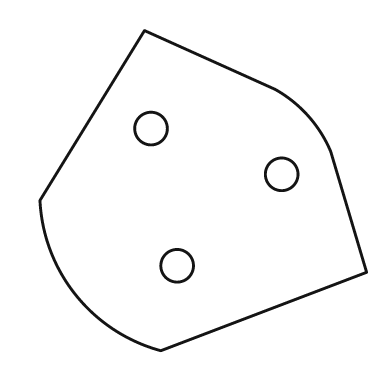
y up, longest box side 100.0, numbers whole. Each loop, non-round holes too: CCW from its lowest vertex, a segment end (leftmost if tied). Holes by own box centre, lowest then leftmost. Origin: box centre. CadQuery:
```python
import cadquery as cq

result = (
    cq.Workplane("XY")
    .moveTo(-13.0, -49.0)
    .lineTo(50.0, -25.0)
    .lineTo(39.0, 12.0)
    .threePointArc((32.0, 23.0), (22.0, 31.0))
    .lineTo(-18.0, 49.0)
    .lineTo(-50.0, -3.0)
    .threePointArc((-39.0, -32.0), (-13.0, -49.0))
    .close()
    .moveTo(-8.0, -23.0)
    .circle(5.0)
    .moveTo(24.0, 5.0)
    .circle(5.0)
    .moveTo(-16.0, 19.0)
    .circle(5.0)
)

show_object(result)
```